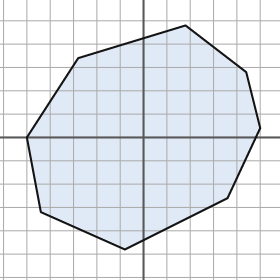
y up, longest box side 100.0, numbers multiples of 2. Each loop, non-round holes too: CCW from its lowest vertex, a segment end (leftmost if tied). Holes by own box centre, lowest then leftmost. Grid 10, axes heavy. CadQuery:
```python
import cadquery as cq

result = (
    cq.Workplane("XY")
    .moveTo(-8.0, -48.0)
    .lineTo(36.0, -26.0)
    .lineTo(50.0, 4.0)
    .lineTo(44.0, 28.0)
    .lineTo(18.0, 48.0)
    .lineTo(-28.0, 34.0)
    .lineTo(-50.0, 0.0)
    .lineTo(-44.0, -32.0)
    .close()
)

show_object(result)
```